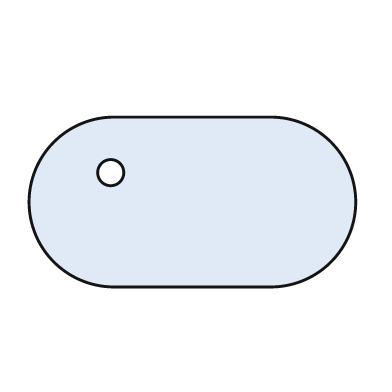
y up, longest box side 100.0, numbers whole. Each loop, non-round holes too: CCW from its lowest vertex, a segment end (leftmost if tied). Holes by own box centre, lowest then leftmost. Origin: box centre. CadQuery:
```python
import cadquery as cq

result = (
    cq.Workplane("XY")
    .moveTo(-24.0, -26.0)
    .lineTo(24.0, -26.0)
    .threePointArc((50.0, 0.0), (24.0, 26.0))
    .lineTo(-24.0, 26.0)
    .threePointArc((-50.0, 0.0), (-24.0, -26.0))
    .close()
    .moveTo(-25.0, 9.0)
    .circle(4.0)
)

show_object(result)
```